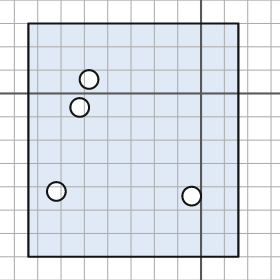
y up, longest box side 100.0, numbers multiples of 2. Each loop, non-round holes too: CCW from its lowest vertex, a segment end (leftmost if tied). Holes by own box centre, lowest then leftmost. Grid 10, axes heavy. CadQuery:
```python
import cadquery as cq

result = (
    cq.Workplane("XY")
    .moveTo(-74.0, -70.0)
    .lineTo(16.0, -70.0)
    .lineTo(16.0, 30.0)
    .lineTo(-74.0, 30.0)
    .close()
    .moveTo(-4.0, -44.0)
    .circle(4.0)
    .moveTo(-62.0, -42.0)
    .circle(4.0)
    .moveTo(-52.0, -6.0)
    .circle(4.0)
    .moveTo(-48.0, 6.0)
    .circle(4.0)
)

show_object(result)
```